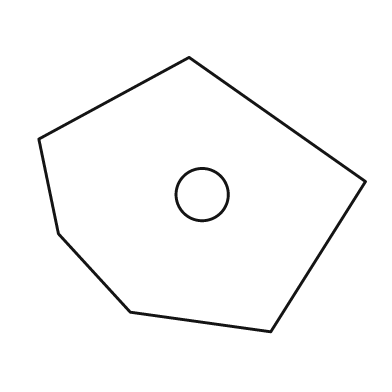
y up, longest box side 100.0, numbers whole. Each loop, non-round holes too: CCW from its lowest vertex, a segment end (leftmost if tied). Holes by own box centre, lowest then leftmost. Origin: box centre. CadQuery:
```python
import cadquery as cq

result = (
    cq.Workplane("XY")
    .moveTo(21.0, -42.0)
    .lineTo(50.0, 4.0)
    .lineTo(-4.0, 42.0)
    .lineTo(-50.0, 17.0)
    .lineTo(-44.0, -12.0)
    .lineTo(-22.0, -36.0)
    .close()
    .moveTo(0.0, 0.0)
    .circle(8.0)
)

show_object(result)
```